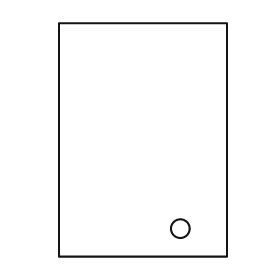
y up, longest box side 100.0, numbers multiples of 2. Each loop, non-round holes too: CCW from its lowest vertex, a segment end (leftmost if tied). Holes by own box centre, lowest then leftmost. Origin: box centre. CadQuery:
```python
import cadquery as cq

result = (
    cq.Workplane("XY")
    .moveTo(-36.0, -50.0)
    .lineTo(36.0, -50.0)
    .lineTo(36.0, 50.0)
    .lineTo(-36.0, 50.0)
    .close()
    .moveTo(16.0, -38.0)
    .circle(4.0)
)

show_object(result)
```